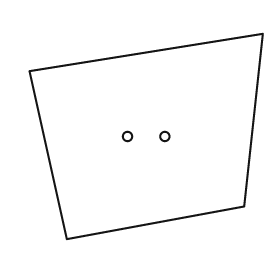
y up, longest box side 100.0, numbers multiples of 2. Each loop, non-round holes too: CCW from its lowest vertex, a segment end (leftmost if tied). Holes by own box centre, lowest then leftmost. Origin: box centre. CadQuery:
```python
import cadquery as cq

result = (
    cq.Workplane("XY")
    .moveTo(-34.0, -44.0)
    .lineTo(42.0, -30.0)
    .lineTo(50.0, 44.0)
    .lineTo(-50.0, 28.0)
    .close()
    .moveTo(-8.0, 0.0)
    .circle(2.0)
    .moveTo(8.0, 0.0)
    .circle(2.0)
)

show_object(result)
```